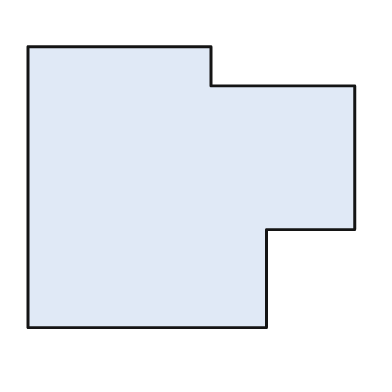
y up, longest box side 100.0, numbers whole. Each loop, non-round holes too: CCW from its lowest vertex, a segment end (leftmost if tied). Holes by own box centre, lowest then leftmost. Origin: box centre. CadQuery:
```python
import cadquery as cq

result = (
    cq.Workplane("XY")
    .moveTo(-50.0, -43.0)
    .lineTo(23.0, -43.0)
    .lineTo(23.0, -13.0)
    .lineTo(50.0, -13.0)
    .lineTo(50.0, 31.0)
    .lineTo(6.0, 31.0)
    .lineTo(6.0, 43.0)
    .lineTo(-50.0, 43.0)
    .close()
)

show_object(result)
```